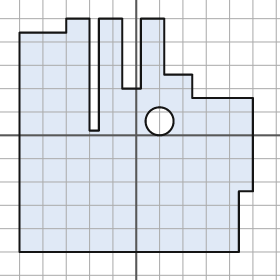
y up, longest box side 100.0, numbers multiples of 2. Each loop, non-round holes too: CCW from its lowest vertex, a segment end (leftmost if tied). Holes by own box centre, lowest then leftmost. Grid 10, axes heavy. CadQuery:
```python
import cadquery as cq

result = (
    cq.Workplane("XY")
    .moveTo(-50.0, -50.0)
    .lineTo(44.0, -50.0)
    .lineTo(44.0, -24.0)
    .lineTo(50.0, -24.0)
    .lineTo(50.0, 16.0)
    .lineTo(24.0, 16.0)
    .lineTo(24.0, 26.0)
    .lineTo(12.0, 26.0)
    .lineTo(12.0, 50.0)
    .lineTo(2.0, 50.0)
    .lineTo(2.0, 20.0)
    .lineTo(-6.0, 20.0)
    .lineTo(-6.0, 50.0)
    .lineTo(-16.0, 50.0)
    .lineTo(-16.0, 2.0)
    .lineTo(-20.0, 2.0)
    .lineTo(-20.0, 50.0)
    .lineTo(-30.0, 50.0)
    .lineTo(-30.0, 44.0)
    .lineTo(-50.0, 44.0)
    .close()
    .moveTo(10.0, 6.0)
    .circle(6.0)
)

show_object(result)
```